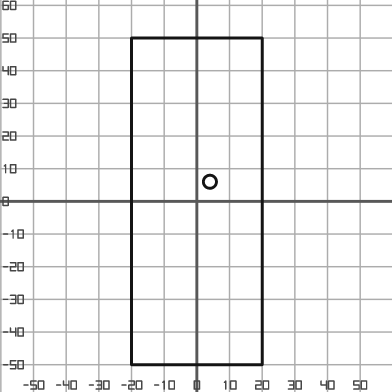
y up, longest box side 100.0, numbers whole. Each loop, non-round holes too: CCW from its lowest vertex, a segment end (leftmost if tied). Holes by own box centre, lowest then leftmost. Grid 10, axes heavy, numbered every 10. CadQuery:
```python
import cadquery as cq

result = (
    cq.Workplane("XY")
    .moveTo(-20.0, -50.0)
    .lineTo(20.0, -50.0)
    .lineTo(20.0, 50.0)
    .lineTo(-20.0, 50.0)
    .close()
    .moveTo(4.0, 6.0)
    .circle(2.0)
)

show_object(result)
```